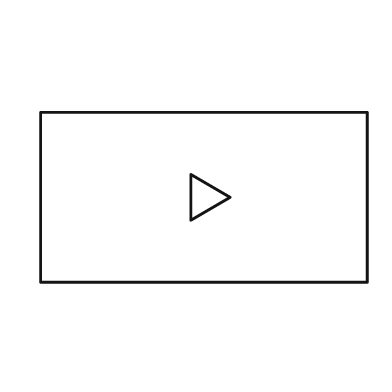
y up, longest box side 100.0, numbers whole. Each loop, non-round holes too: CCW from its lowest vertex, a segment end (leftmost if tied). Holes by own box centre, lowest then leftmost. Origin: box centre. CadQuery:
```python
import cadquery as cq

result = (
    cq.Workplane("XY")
    .moveTo(-50.0, -26.0)
    .lineTo(50.0, -26.0)
    .lineTo(50.0, 26.0)
    .lineTo(-50.0, 26.0)
    .close()
    .moveTo(-4.0, -7.0)
    .lineTo(8.0, 0.0)
    .lineTo(-4.0, 7.0)
    .close()
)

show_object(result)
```